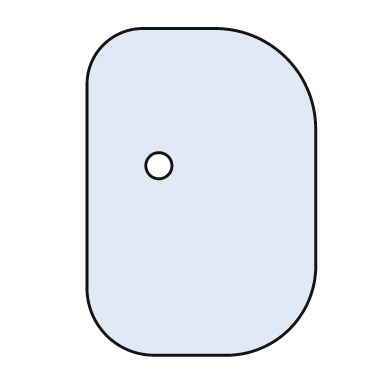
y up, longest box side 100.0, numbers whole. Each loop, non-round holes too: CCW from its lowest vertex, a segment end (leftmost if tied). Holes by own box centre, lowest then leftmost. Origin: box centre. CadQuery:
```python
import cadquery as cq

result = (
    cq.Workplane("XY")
    .moveTo(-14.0, -50.0)
    .lineTo(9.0, -50.0)
    .threePointArc((27.0, -42.0), (35.0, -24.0))
    .lineTo(35.0, 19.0)
    .threePointArc((26.0, 41.0), (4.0, 50.0))
    .lineTo(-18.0, 50.0)
    .threePointArc((-30.0, 45.0), (-35.0, 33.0))
    .lineTo(-35.0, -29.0)
    .threePointArc((-29.0, -44.0), (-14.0, -50.0))
    .close()
    .moveTo(-13.0, 8.0)
    .circle(4.0)
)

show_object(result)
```